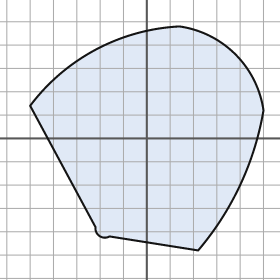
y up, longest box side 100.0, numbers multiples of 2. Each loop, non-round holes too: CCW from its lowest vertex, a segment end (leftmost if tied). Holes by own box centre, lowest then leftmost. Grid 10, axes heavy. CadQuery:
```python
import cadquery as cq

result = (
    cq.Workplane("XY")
    .moveTo(22.0, -48.0)
    .threePointArc((40.0, -20.0), (50.0, 12.0))
    .threePointArc((38.0, 36.0), (14.0, 48.0))
    .threePointArc((-22.0, 38.0), (-50.0, 14.0))
    .lineTo(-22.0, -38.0)
    .threePointArc((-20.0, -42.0), (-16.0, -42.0))
    .close()
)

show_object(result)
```